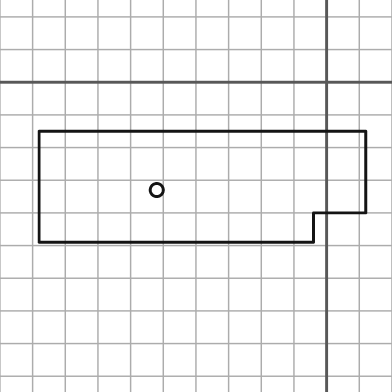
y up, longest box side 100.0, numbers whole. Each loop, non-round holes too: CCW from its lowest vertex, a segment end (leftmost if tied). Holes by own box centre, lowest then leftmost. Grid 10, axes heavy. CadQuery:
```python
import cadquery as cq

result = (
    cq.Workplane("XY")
    .moveTo(-88.0, -49.0)
    .lineTo(-4.0, -49.0)
    .lineTo(-4.0, -40.0)
    .lineTo(12.0, -40.0)
    .lineTo(12.0, -15.0)
    .lineTo(-88.0, -15.0)
    .close()
    .moveTo(-52.0, -33.0)
    .circle(2.0)
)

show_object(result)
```